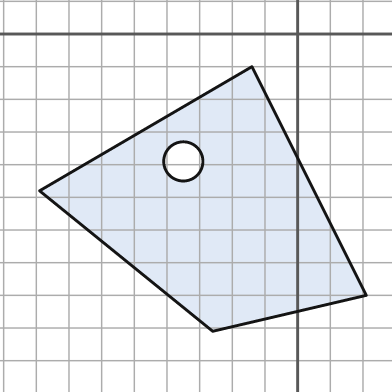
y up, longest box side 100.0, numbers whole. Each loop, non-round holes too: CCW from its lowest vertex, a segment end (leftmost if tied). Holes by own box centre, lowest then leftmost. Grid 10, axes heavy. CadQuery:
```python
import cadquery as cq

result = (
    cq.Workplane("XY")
    .moveTo(-26.0, -91.0)
    .lineTo(21.0, -80.0)
    .lineTo(-14.0, -10.0)
    .lineTo(-79.0, -48.0)
    .close()
    .moveTo(-35.0, -39.0)
    .circle(6.0)
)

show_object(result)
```